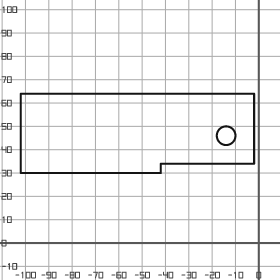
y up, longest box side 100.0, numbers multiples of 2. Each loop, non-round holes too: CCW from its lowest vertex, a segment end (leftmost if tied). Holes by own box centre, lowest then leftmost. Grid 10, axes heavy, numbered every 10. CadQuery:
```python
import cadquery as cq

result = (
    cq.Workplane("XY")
    .moveTo(-102.0, 30.0)
    .lineTo(-42.0, 30.0)
    .lineTo(-42.0, 34.0)
    .lineTo(-2.0, 34.0)
    .lineTo(-2.0, 64.0)
    .lineTo(-102.0, 64.0)
    .close()
    .moveTo(-14.0, 46.0)
    .circle(4.0)
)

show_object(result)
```